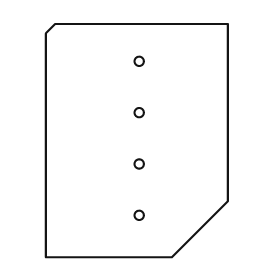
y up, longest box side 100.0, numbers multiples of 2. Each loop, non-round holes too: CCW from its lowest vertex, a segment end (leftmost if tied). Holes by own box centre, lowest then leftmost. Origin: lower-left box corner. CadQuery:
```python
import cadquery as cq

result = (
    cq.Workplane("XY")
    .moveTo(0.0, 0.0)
    .lineTo(54.0, 0.0)
    .lineTo(78.0, 24.0)
    .lineTo(78.0, 100.0)
    .lineTo(4.0, 100.0)
    .lineTo(0.0, 96.0)
    .close()
    .moveTo(40.0, 18.0)
    .circle(2.0)
    .moveTo(40.0, 40.0)
    .circle(2.0)
    .moveTo(40.0, 62.0)
    .circle(2.0)
    .moveTo(40.0, 84.0)
    .circle(2.0)
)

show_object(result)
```